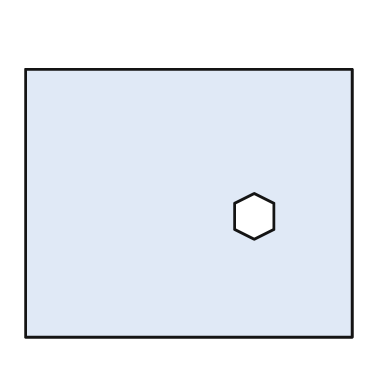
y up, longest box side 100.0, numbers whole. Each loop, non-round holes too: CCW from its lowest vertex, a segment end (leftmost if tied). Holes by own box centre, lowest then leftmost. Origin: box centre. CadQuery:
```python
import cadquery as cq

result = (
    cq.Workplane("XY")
    .moveTo(-50.0, -41.0)
    .lineTo(50.0, -41.0)
    .lineTo(50.0, 41.0)
    .lineTo(-50.0, 41.0)
    .close()
    .moveTo(20.0, -11.0)
    .lineTo(26.0, -8.0)
    .lineTo(26.0, 0.0)
    .lineTo(20.0, 3.0)
    .lineTo(14.0, 0.0)
    .lineTo(14.0, -8.0)
    .close()
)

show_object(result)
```